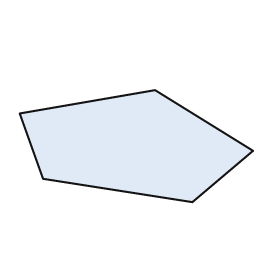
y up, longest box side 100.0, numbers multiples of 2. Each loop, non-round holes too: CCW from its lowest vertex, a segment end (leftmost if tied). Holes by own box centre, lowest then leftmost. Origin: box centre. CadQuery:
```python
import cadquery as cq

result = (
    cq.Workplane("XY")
    .moveTo(24.0, -24.0)
    .lineTo(50.0, -2.0)
    .lineTo(8.0, 24.0)
    .lineTo(-50.0, 14.0)
    .lineTo(-40.0, -14.0)
    .close()
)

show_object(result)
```